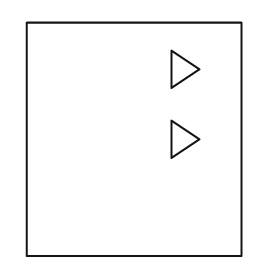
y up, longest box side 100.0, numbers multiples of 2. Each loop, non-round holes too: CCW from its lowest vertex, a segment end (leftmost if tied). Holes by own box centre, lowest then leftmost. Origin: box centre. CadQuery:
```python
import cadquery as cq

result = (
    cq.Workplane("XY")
    .moveTo(-46.0, -50.0)
    .lineTo(46.0, -50.0)
    .lineTo(46.0, 50.0)
    .lineTo(-46.0, 50.0)
    .close()
    .moveTo(16.0, -8.0)
    .lineTo(28.0, 0.0)
    .lineTo(16.0, 8.0)
    .close()
    .moveTo(16.0, 22.0)
    .lineTo(28.0, 30.0)
    .lineTo(16.0, 38.0)
    .close()
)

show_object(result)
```